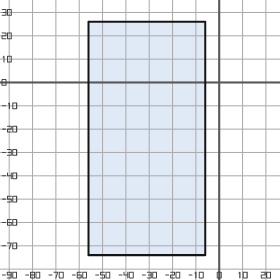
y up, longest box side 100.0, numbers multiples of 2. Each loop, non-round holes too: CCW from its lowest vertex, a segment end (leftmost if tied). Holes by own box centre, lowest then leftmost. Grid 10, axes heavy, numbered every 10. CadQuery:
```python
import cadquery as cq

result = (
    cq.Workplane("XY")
    .moveTo(-56.0, -74.0)
    .lineTo(-6.0, -74.0)
    .lineTo(-6.0, 26.0)
    .lineTo(-56.0, 26.0)
    .close()
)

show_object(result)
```